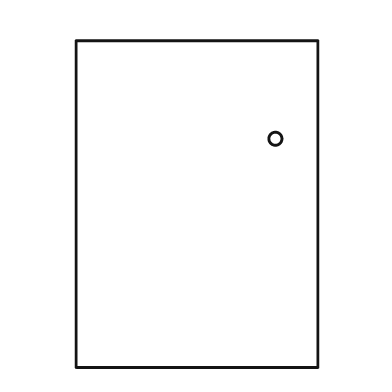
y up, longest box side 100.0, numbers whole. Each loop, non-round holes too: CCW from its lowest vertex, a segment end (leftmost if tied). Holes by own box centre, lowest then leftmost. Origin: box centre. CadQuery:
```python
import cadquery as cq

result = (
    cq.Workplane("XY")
    .moveTo(-37.0, -50.0)
    .lineTo(37.0, -50.0)
    .lineTo(37.0, 50.0)
    .lineTo(-37.0, 50.0)
    .close()
    .moveTo(24.0, 20.0)
    .circle(2.0)
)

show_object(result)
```